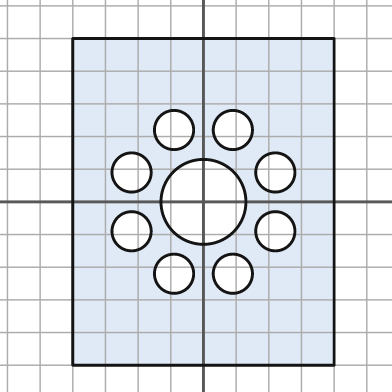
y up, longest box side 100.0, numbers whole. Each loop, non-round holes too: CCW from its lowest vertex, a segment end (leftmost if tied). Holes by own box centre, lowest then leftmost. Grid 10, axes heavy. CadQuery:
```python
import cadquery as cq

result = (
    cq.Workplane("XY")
    .moveTo(-40.0, -50.0)
    .lineTo(40.0, -50.0)
    .lineTo(40.0, 50.0)
    .lineTo(-40.0, 50.0)
    .close()
    .moveTo(-9.0, -22.0)
    .circle(6.0)
    .moveTo(9.0, -22.0)
    .circle(6.0)
    .moveTo(-22.0, -9.0)
    .circle(6.0)
    .moveTo(22.0, -9.0)
    .circle(6.0)
    .moveTo(0.0, 0.0)
    .circle(13.0)
    .moveTo(-22.0, 9.0)
    .circle(6.0)
    .moveTo(22.0, 9.0)
    .circle(6.0)
    .moveTo(-9.0, 22.0)
    .circle(6.0)
    .moveTo(9.0, 22.0)
    .circle(6.0)
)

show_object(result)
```